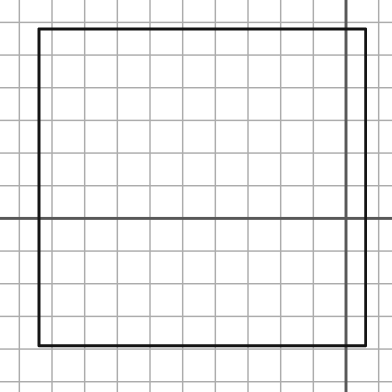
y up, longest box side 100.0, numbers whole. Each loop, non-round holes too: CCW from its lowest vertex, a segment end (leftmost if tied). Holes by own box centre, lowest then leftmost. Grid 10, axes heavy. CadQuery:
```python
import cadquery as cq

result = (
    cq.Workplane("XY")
    .moveTo(-94.0, -39.0)
    .lineTo(6.0, -39.0)
    .lineTo(6.0, 58.0)
    .lineTo(-94.0, 58.0)
    .close()
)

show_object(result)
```